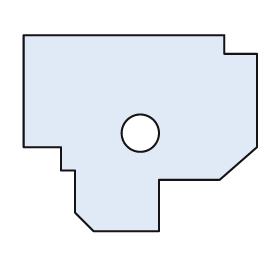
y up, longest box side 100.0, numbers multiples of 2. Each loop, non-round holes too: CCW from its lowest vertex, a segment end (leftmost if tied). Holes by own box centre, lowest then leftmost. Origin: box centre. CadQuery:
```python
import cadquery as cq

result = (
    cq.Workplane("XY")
    .moveTo(-20.0, -42.0)
    .lineTo(8.0, -42.0)
    .lineTo(8.0, -20.0)
    .lineTo(34.0, -20.0)
    .lineTo(50.0, -6.0)
    .lineTo(50.0, 34.0)
    .lineTo(36.0, 34.0)
    .lineTo(36.0, 42.0)
    .lineTo(-50.0, 42.0)
    .lineTo(-50.0, -6.0)
    .lineTo(-34.0, -6.0)
    .lineTo(-34.0, -16.0)
    .lineTo(-28.0, -16.0)
    .lineTo(-28.0, -34.0)
    .close()
    .moveTo(0.0, 0.0)
    .circle(8.0)
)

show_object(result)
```